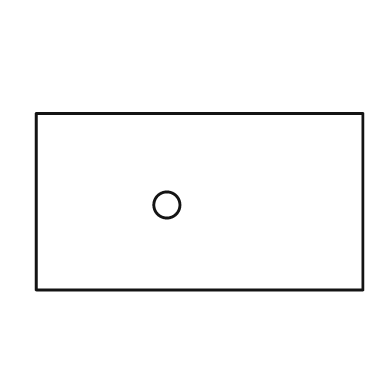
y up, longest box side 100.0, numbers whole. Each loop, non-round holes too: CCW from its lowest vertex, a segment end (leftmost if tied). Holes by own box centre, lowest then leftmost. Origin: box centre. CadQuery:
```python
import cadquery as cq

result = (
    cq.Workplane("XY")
    .moveTo(-50.0, -27.0)
    .lineTo(50.0, -27.0)
    .lineTo(50.0, 27.0)
    .lineTo(-50.0, 27.0)
    .close()
    .moveTo(-10.0, -1.0)
    .circle(4.0)
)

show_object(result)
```